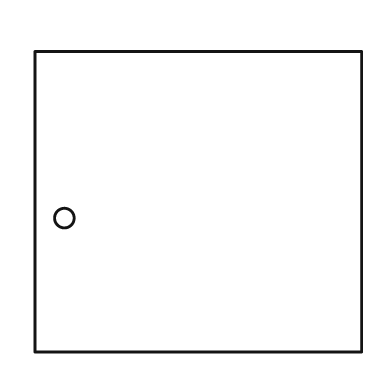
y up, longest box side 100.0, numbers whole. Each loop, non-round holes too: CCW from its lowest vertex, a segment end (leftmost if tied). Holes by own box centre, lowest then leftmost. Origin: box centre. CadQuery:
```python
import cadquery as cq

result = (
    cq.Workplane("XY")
    .moveTo(-50.0, -46.0)
    .lineTo(50.0, -46.0)
    .lineTo(50.0, 46.0)
    .lineTo(-50.0, 46.0)
    .close()
    .moveTo(-41.0, -5.0)
    .circle(3.0)
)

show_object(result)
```